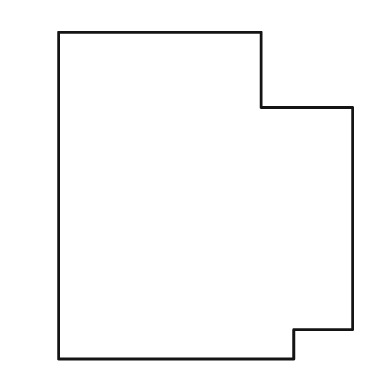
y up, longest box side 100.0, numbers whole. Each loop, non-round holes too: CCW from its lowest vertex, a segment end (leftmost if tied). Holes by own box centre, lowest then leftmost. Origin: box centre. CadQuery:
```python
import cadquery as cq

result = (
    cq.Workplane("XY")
    .moveTo(-45.0, -50.0)
    .lineTo(27.0, -50.0)
    .lineTo(27.0, -41.0)
    .lineTo(45.0, -41.0)
    .lineTo(45.0, 27.0)
    .lineTo(17.0, 27.0)
    .lineTo(17.0, 50.0)
    .lineTo(-45.0, 50.0)
    .close()
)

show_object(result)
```